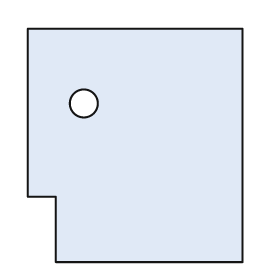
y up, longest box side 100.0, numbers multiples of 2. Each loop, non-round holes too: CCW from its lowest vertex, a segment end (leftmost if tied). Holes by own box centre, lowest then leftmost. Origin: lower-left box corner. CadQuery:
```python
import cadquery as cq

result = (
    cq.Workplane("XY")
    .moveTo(12.0, 0.0)
    .lineTo(92.0, 0.0)
    .lineTo(92.0, 100.0)
    .lineTo(0.0, 100.0)
    .lineTo(0.0, 28.0)
    .lineTo(12.0, 28.0)
    .close()
    .moveTo(24.0, 68.0)
    .circle(6.0)
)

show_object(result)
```